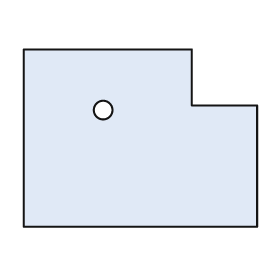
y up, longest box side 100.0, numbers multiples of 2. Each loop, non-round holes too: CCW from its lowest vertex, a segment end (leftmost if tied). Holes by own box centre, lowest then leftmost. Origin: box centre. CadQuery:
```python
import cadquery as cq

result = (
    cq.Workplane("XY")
    .moveTo(-50.0, -38.0)
    .lineTo(50.0, -38.0)
    .lineTo(50.0, 14.0)
    .lineTo(22.0, 14.0)
    .lineTo(22.0, 38.0)
    .lineTo(-50.0, 38.0)
    .close()
    .moveTo(-16.0, 12.0)
    .circle(4.0)
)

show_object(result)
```